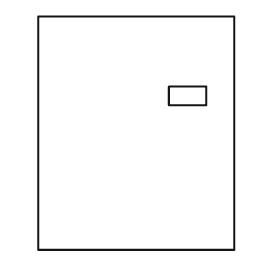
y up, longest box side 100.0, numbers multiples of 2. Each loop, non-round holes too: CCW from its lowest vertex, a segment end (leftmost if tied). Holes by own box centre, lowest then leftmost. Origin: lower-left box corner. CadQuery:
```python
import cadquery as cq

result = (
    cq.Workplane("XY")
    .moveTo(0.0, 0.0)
    .lineTo(84.0, 0.0)
    .lineTo(84.0, 100.0)
    .lineTo(0.0, 100.0)
    .close()
    .moveTo(56.0, 62.0)
    .lineTo(72.0, 62.0)
    .lineTo(72.0, 70.0)
    .lineTo(56.0, 70.0)
    .close()
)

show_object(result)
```